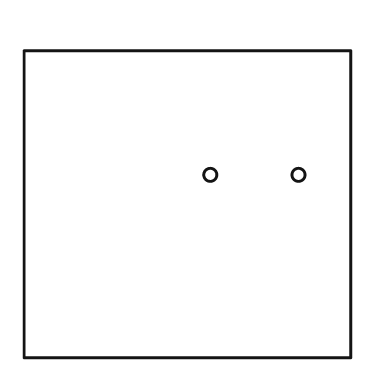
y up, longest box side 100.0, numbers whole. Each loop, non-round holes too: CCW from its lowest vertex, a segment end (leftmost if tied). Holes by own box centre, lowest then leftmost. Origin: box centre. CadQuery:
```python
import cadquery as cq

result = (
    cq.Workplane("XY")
    .moveTo(-50.0, -47.0)
    .lineTo(50.0, -47.0)
    .lineTo(50.0, 47.0)
    .lineTo(-50.0, 47.0)
    .close()
    .moveTo(7.0, 9.0)
    .circle(2.0)
    .moveTo(34.0, 9.0)
    .circle(2.0)
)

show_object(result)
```